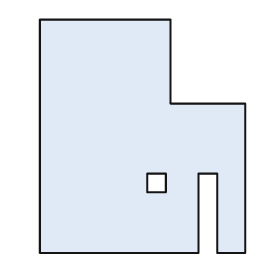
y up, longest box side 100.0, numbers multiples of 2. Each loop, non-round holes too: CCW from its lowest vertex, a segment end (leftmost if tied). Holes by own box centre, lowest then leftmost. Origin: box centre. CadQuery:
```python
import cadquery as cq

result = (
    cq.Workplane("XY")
    .moveTo(-44.0, -50.0)
    .lineTo(24.0, -50.0)
    .lineTo(24.0, -16.0)
    .lineTo(32.0, -16.0)
    .lineTo(32.0, -50.0)
    .lineTo(44.0, -50.0)
    .lineTo(44.0, 14.0)
    .lineTo(12.0, 14.0)
    .lineTo(12.0, 50.0)
    .lineTo(-44.0, 50.0)
    .close()
    .moveTo(2.0, -24.0)
    .lineTo(10.0, -24.0)
    .lineTo(10.0, -16.0)
    .lineTo(2.0, -16.0)
    .close()
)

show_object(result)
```